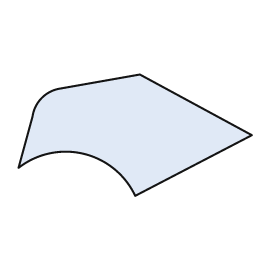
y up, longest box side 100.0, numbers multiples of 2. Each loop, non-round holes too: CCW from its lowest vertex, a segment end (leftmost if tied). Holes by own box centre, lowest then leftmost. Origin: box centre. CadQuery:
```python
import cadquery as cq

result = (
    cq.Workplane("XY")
    .moveTo(0.0, -26.0)
    .lineTo(50.0, 0.0)
    .lineTo(2.0, 26.0)
    .lineTo(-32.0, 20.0)
    .threePointArc((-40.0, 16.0), (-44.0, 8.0))
    .lineTo(-50.0, -14.0)
    .threePointArc((-22.0, -8.0), (0.0, -26.0))
    .close()
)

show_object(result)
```